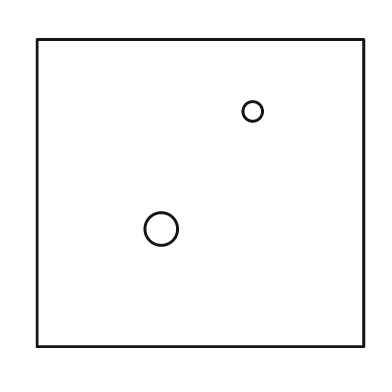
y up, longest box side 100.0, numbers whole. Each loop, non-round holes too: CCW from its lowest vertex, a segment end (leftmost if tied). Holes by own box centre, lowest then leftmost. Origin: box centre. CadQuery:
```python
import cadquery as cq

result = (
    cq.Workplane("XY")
    .moveTo(-50.0, -47.0)
    .lineTo(50.0, -47.0)
    .lineTo(50.0, 47.0)
    .lineTo(-50.0, 47.0)
    .close()
    .moveTo(-12.0, -11.0)
    .circle(5.0)
    .moveTo(16.0, 25.0)
    .circle(3.0)
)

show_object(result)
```